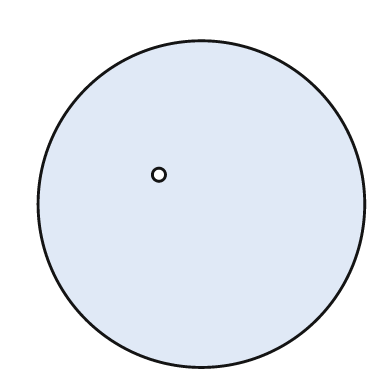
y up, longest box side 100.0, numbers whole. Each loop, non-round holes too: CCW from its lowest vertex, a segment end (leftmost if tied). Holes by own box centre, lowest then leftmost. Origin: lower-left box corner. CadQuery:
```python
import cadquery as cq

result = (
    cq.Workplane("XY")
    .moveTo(50.0, 50.0)
    .circle(50.0)
    .moveTo(37.0, 59.0)
    .circle(2.0)
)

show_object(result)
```